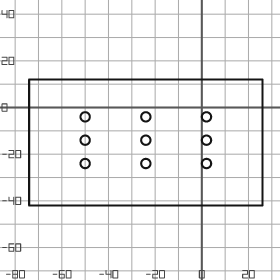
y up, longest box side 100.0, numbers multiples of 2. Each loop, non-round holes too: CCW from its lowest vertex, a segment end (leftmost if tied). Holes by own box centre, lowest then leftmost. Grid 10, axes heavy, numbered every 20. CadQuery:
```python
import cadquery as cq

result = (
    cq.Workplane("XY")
    .moveTo(-74.0, -42.0)
    .lineTo(26.0, -42.0)
    .lineTo(26.0, 12.0)
    .lineTo(-74.0, 12.0)
    .close()
    .moveTo(-50.0, -24.0)
    .circle(2.0)
    .moveTo(-24.0, -24.0)
    .circle(2.0)
    .moveTo(2.0, -24.0)
    .circle(2.0)
    .moveTo(-50.0, -14.0)
    .circle(2.0)
    .moveTo(-24.0, -14.0)
    .circle(2.0)
    .moveTo(2.0, -14.0)
    .circle(2.0)
    .moveTo(-50.0, -4.0)
    .circle(2.0)
    .moveTo(-24.0, -4.0)
    .circle(2.0)
    .moveTo(2.0, -4.0)
    .circle(2.0)
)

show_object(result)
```